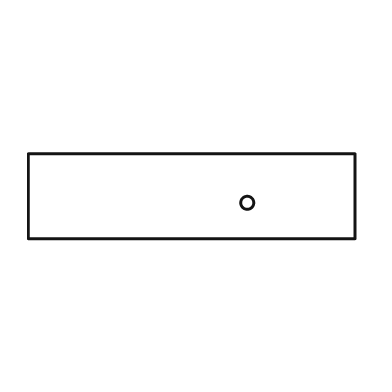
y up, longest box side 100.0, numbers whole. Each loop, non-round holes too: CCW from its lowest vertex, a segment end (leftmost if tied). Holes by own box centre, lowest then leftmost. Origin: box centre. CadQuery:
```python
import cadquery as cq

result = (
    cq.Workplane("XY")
    .moveTo(-50.0, -13.0)
    .lineTo(50.0, -13.0)
    .lineTo(50.0, 13.0)
    .lineTo(-50.0, 13.0)
    .close()
    .moveTo(17.0, -2.0)
    .circle(2.0)
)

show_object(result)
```